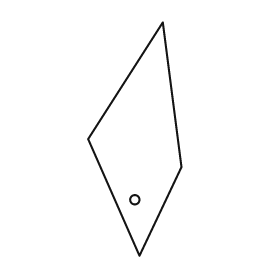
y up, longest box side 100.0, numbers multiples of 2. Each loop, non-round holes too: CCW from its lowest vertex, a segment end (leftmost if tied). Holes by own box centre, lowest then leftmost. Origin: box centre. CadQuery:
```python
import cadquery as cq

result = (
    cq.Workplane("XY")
    .moveTo(2.0, -50.0)
    .lineTo(20.0, -12.0)
    .lineTo(12.0, 50.0)
    .lineTo(-20.0, 0.0)
    .close()
    .moveTo(0.0, -26.0)
    .circle(2.0)
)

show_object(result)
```